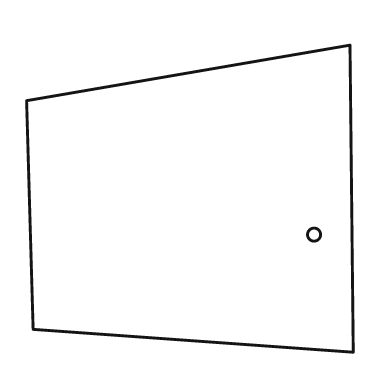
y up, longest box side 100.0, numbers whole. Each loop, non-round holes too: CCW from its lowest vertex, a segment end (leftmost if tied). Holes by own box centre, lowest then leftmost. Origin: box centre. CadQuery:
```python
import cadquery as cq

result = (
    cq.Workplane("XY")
    .moveTo(50.0, -47.0)
    .lineTo(49.0, 47.0)
    .lineTo(-50.0, 30.0)
    .lineTo(-48.0, -40.0)
    .close()
    .moveTo(38.0, -11.0)
    .circle(2.0)
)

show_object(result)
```